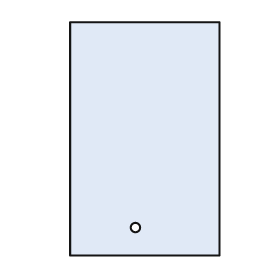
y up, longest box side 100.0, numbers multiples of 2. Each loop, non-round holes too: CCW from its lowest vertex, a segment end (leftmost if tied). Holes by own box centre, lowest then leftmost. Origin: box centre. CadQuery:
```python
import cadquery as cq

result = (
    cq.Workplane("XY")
    .moveTo(-32.0, -50.0)
    .lineTo(32.0, -50.0)
    .lineTo(32.0, 50.0)
    .lineTo(-32.0, 50.0)
    .close()
    .moveTo(-4.0, -38.0)
    .circle(2.0)
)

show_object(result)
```